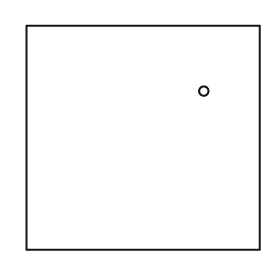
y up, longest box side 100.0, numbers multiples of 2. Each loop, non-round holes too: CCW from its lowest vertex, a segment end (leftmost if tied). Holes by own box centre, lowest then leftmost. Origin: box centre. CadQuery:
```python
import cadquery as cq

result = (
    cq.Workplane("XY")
    .moveTo(-50.0, -48.0)
    .lineTo(50.0, -48.0)
    .lineTo(50.0, 48.0)
    .lineTo(-50.0, 48.0)
    .close()
    .moveTo(26.0, 20.0)
    .circle(2.0)
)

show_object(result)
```